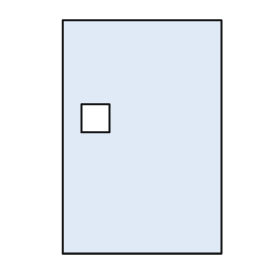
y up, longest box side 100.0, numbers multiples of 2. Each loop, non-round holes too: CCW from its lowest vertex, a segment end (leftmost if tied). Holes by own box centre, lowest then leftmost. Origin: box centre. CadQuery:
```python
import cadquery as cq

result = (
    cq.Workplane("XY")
    .moveTo(-34.0, -50.0)
    .lineTo(34.0, -50.0)
    .lineTo(34.0, 50.0)
    .lineTo(-34.0, 50.0)
    .close()
    .moveTo(-26.0, 2.0)
    .lineTo(-14.0, 2.0)
    .lineTo(-14.0, 14.0)
    .lineTo(-26.0, 14.0)
    .close()
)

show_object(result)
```